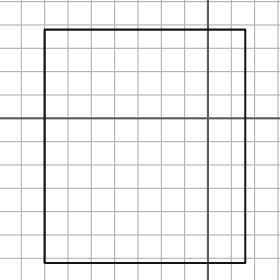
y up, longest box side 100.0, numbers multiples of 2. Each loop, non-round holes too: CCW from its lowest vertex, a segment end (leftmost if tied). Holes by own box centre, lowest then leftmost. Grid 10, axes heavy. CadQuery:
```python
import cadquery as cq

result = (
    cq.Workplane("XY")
    .moveTo(-70.0, -62.0)
    .lineTo(16.0, -62.0)
    .lineTo(16.0, 38.0)
    .lineTo(-70.0, 38.0)
    .close()
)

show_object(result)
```